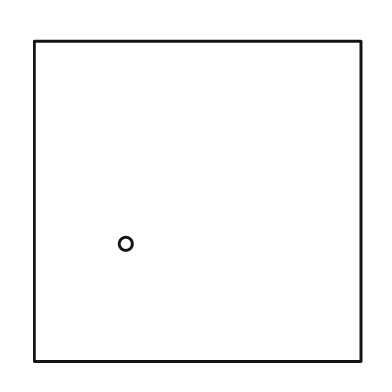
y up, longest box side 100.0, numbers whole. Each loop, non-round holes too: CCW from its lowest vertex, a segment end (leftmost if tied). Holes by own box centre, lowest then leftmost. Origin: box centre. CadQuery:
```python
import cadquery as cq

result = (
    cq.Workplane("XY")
    .moveTo(-50.0, -49.0)
    .lineTo(50.0, -49.0)
    .lineTo(50.0, 49.0)
    .lineTo(-50.0, 49.0)
    .close()
    .moveTo(-22.0, -13.0)
    .circle(2.0)
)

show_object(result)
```